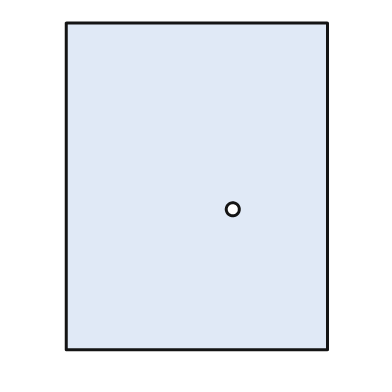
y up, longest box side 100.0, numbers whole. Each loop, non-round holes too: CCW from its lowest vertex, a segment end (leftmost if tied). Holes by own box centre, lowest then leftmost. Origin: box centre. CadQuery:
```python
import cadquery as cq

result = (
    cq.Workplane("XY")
    .moveTo(-40.0, -50.0)
    .lineTo(40.0, -50.0)
    .lineTo(40.0, 50.0)
    .lineTo(-40.0, 50.0)
    .close()
    .moveTo(11.0, -7.0)
    .circle(2.0)
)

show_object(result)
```